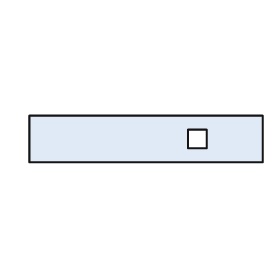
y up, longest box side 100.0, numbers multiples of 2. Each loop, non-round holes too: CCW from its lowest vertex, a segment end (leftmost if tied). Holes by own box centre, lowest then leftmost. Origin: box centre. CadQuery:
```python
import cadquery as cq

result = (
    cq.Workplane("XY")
    .moveTo(-50.0, -10.0)
    .lineTo(50.0, -10.0)
    .lineTo(50.0, 10.0)
    .lineTo(-50.0, 10.0)
    .close()
    .moveTo(18.0, -4.0)
    .lineTo(26.0, -4.0)
    .lineTo(26.0, 4.0)
    .lineTo(18.0, 4.0)
    .close()
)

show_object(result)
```